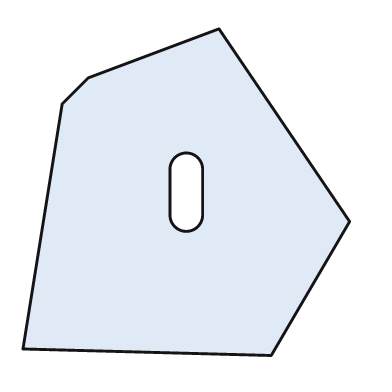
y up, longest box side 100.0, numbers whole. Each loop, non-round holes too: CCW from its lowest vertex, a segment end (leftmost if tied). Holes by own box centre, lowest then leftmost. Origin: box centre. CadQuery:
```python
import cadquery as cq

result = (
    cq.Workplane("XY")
    .moveTo(26.0, -50.0)
    .lineTo(50.0, -9.0)
    .lineTo(10.0, 50.0)
    .lineTo(-30.0, 35.0)
    .lineTo(-38.0, 27.0)
    .lineTo(-50.0, -48.0)
    .close()
    .moveTo(-5.0, -7.0)
    .threePointArc((0.0, -12.0), (5.0, -7.0))
    .lineTo(5.0, 7.0)
    .threePointArc((0.0, 12.0), (-5.0, 7.0))
    .close()
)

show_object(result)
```